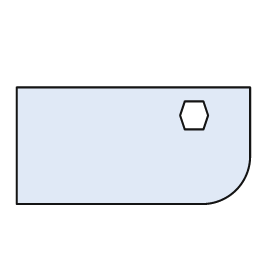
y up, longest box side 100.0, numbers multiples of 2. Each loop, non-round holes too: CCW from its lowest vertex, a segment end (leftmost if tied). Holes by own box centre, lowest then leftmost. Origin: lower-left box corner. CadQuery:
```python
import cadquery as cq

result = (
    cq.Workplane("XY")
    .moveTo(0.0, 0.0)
    .lineTo(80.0, 0.0)
    .threePointArc((94.0, 6.0), (100.0, 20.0))
    .lineTo(100.0, 50.0)
    .lineTo(0.0, 50.0)
    .close()
    .moveTo(72.0, 32.0)
    .lineTo(80.0, 32.0)
    .lineTo(82.0, 38.0)
    .lineTo(80.0, 44.0)
    .lineTo(72.0, 44.0)
    .lineTo(70.0, 38.0)
    .close()
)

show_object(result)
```